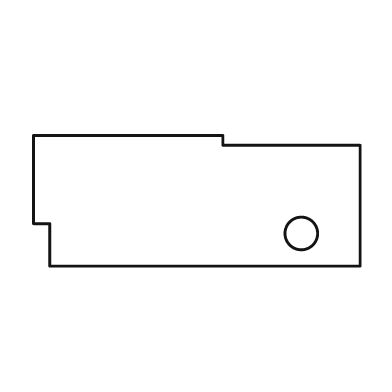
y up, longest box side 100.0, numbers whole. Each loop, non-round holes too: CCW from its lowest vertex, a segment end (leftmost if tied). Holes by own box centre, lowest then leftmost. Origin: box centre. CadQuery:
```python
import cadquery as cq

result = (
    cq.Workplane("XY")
    .moveTo(-45.0, -20.0)
    .lineTo(50.0, -20.0)
    .lineTo(50.0, 17.0)
    .lineTo(8.0, 17.0)
    .lineTo(8.0, 20.0)
    .lineTo(-50.0, 20.0)
    .lineTo(-50.0, -7.0)
    .lineTo(-45.0, -7.0)
    .close()
    .moveTo(32.0, -10.0)
    .circle(5.0)
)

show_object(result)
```